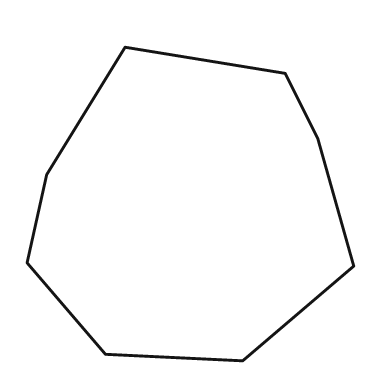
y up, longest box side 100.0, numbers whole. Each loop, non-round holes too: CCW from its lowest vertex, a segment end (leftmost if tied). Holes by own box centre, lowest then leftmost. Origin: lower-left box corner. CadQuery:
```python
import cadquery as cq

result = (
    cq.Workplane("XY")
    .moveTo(66.0, 0.0)
    .lineTo(100.0, 29.0)
    .lineTo(89.0, 68.0)
    .lineTo(79.0, 88.0)
    .lineTo(30.0, 96.0)
    .lineTo(6.0, 57.0)
    .lineTo(0.0, 30.0)
    .lineTo(24.0, 2.0)
    .close()
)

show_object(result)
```